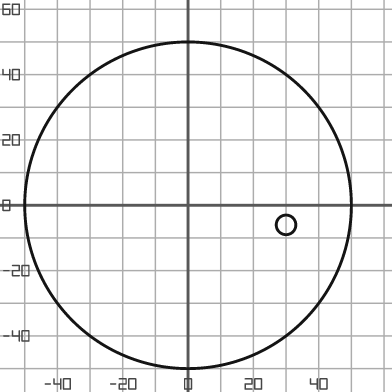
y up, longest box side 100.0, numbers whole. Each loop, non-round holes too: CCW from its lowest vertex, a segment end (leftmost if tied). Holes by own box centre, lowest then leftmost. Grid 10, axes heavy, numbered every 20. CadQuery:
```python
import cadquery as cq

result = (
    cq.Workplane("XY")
    .moveTo(0.0, 0.0)
    .circle(50.0)
    .moveTo(30.0, -6.0)
    .circle(3.0)
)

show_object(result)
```